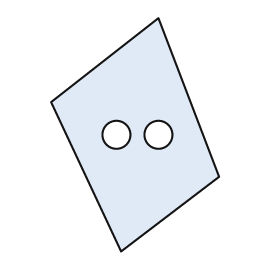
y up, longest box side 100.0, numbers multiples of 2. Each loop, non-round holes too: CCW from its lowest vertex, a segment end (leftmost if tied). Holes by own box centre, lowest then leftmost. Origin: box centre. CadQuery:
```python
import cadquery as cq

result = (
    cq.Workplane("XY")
    .moveTo(-6.0, -50.0)
    .lineTo(36.0, -18.0)
    .lineTo(10.0, 50.0)
    .lineTo(-36.0, 14.0)
    .close()
    .moveTo(-8.0, 0.0)
    .circle(6.0)
    .moveTo(10.0, 0.0)
    .circle(6.0)
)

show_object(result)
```